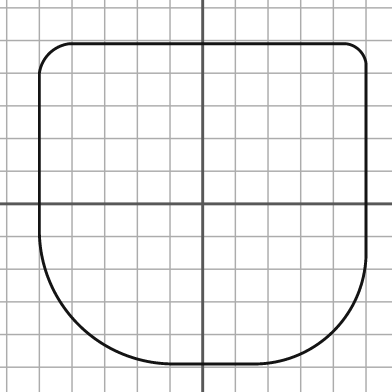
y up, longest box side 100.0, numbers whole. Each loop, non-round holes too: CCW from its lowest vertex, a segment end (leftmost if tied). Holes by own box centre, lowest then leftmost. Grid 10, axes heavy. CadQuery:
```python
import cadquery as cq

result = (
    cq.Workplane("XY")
    .moveTo(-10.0, -49.0)
    .lineTo(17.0, -49.0)
    .threePointArc((40.0, -39.0), (50.0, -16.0))
    .lineTo(50.0, 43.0)
    .threePointArc((48.0, 47.0), (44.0, 49.0))
    .lineTo(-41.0, 49.0)
    .threePointArc((-47.0, 46.0), (-50.0, 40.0))
    .lineTo(-50.0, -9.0)
    .threePointArc((-38.0, -37.0), (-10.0, -49.0))
    .close()
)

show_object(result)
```